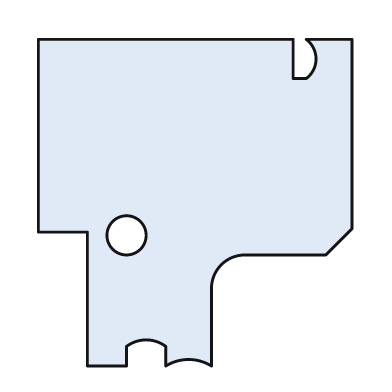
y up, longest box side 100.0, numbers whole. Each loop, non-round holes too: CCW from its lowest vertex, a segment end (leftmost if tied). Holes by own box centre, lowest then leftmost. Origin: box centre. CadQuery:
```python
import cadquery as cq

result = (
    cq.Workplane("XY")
    .moveTo(-33.0, -50.0)
    .lineTo(-21.0, -50.0)
    .lineTo(-21.0, -44.0)
    .threePointArc((-15.0, -42.0), (-9.0, -44.0))
    .lineTo(-9.0, -50.0)
    .threePointArc((-2.0, -48.0), (5.0, -50.0))
    .lineTo(5.0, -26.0)
    .threePointArc((8.0, -19.0), (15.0, -16.0))
    .lineTo(40.0, -16.0)
    .lineTo(48.0, -8.0)
    .lineTo(48.0, 50.0)
    .lineTo(34.0, 50.0)
    .threePointArc((37.0, 44.0), (34.0, 38.0))
    .lineTo(30.0, 38.0)
    .lineTo(30.0, 50.0)
    .lineTo(-48.0, 50.0)
    .lineTo(-48.0, -9.0)
    .lineTo(-33.0, -9.0)
    .close()
    .moveTo(-21.0, -10.0)
    .circle(6.0)
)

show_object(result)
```